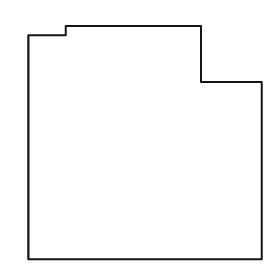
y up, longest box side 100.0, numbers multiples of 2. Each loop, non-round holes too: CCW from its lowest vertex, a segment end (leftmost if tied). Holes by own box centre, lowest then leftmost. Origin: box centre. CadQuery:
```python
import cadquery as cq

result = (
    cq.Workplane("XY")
    .moveTo(-50.0, -50.0)
    .lineTo(50.0, -50.0)
    .lineTo(50.0, 26.0)
    .lineTo(24.0, 26.0)
    .lineTo(24.0, 50.0)
    .lineTo(-34.0, 50.0)
    .lineTo(-34.0, 46.0)
    .lineTo(-50.0, 46.0)
    .close()
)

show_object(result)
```